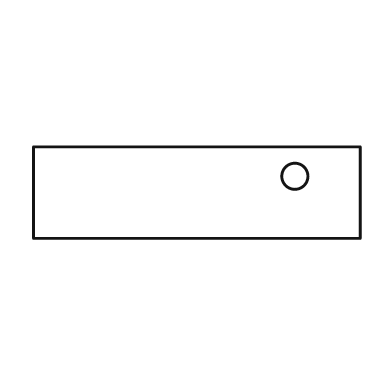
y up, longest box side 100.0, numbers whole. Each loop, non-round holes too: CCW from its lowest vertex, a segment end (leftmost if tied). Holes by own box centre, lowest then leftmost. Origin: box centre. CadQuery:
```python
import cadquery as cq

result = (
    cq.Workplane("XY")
    .moveTo(-50.0, -14.0)
    .lineTo(50.0, -14.0)
    .lineTo(50.0, 14.0)
    .lineTo(-50.0, 14.0)
    .close()
    .moveTo(30.0, 5.0)
    .circle(4.0)
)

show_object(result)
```